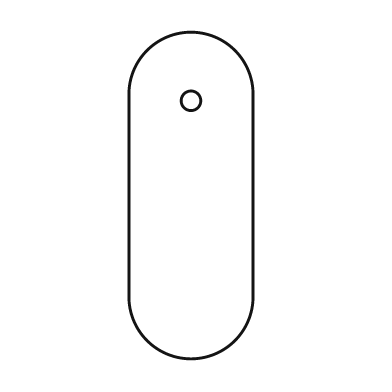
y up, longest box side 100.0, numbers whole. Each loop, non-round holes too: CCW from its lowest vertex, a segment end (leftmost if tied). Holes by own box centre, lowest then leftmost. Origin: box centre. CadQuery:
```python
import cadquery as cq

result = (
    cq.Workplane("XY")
    .moveTo(-19.0, -31.0)
    .threePointArc((0.0, -50.0), (19.0, -31.0))
    .lineTo(19.0, 31.0)
    .threePointArc((0.0, 50.0), (-19.0, 31.0))
    .close()
    .moveTo(0.0, 29.0)
    .circle(3.0)
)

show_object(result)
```